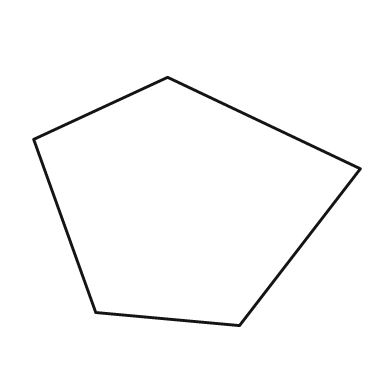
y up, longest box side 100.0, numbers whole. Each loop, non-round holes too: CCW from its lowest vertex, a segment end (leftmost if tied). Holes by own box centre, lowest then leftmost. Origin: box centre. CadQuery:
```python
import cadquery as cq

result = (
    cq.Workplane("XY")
    .moveTo(13.0, -38.0)
    .lineTo(50.0, 10.0)
    .lineTo(-9.0, 38.0)
    .lineTo(-50.0, 19.0)
    .lineTo(-31.0, -34.0)
    .close()
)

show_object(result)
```